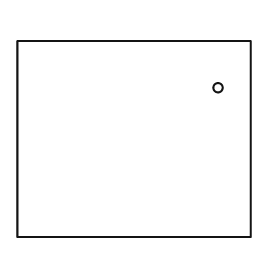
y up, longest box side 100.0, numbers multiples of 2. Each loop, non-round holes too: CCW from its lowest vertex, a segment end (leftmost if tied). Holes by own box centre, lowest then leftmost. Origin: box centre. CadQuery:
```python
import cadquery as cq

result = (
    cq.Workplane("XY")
    .moveTo(-50.0, -42.0)
    .lineTo(50.0, -42.0)
    .lineTo(50.0, 42.0)
    .lineTo(-50.0, 42.0)
    .close()
    .moveTo(36.0, 22.0)
    .circle(2.0)
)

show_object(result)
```